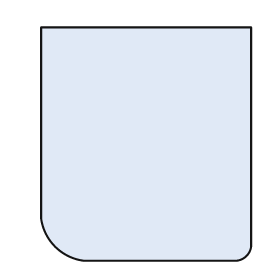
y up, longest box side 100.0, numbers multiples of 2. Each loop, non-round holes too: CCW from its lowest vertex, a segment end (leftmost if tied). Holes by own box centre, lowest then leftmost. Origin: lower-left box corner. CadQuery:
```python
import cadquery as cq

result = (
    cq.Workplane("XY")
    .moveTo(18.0, 0.0)
    .lineTo(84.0, 0.0)
    .threePointArc((88.0, 2.0), (90.0, 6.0))
    .lineTo(90.0, 100.0)
    .lineTo(0.0, 100.0)
    .lineTo(0.0, 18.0)
    .threePointArc((6.0, 6.0), (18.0, 0.0))
    .close()
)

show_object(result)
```